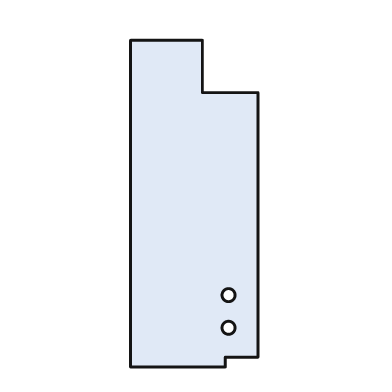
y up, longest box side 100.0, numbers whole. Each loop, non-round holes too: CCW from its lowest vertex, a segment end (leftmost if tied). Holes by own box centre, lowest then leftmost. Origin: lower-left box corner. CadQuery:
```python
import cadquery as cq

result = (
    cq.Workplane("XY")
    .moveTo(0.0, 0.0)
    .lineTo(29.0, 0.0)
    .lineTo(29.0, 3.0)
    .lineTo(39.0, 3.0)
    .lineTo(39.0, 84.0)
    .lineTo(22.0, 84.0)
    .lineTo(22.0, 100.0)
    .lineTo(0.0, 100.0)
    .close()
    .moveTo(30.0, 12.0)
    .circle(2.0)
    .moveTo(30.0, 22.0)
    .circle(2.0)
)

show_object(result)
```